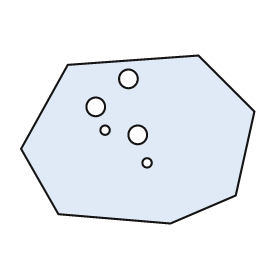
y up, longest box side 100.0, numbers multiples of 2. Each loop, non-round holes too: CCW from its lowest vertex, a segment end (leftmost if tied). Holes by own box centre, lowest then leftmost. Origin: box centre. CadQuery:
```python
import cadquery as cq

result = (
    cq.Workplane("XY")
    .moveTo(14.0, -36.0)
    .lineTo(42.0, -24.0)
    .lineTo(50.0, 12.0)
    .lineTo(26.0, 36.0)
    .lineTo(-30.0, 32.0)
    .lineTo(-50.0, -4.0)
    .lineTo(-34.0, -32.0)
    .close()
    .moveTo(4.0, -10.0)
    .circle(2.0)
    .moveTo(0.0, 2.0)
    .circle(4.0)
    .moveTo(-14.0, 4.0)
    .circle(2.0)
    .moveTo(-18.0, 14.0)
    .circle(4.0)
    .moveTo(-4.0, 26.0)
    .circle(4.0)
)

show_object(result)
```